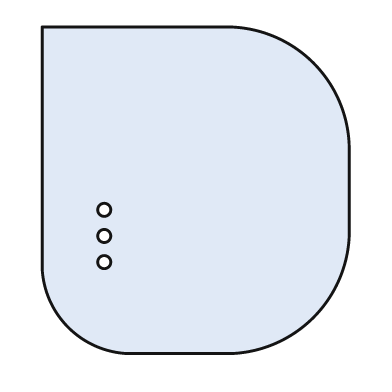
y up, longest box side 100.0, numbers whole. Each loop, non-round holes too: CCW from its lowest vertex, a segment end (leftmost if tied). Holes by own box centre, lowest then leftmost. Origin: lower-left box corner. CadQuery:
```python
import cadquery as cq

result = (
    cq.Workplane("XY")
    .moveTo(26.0, 0.0)
    .lineTo(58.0, 0.0)
    .threePointArc((83.0, 11.0), (94.0, 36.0))
    .lineTo(94.0, 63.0)
    .threePointArc((83.0, 89.0), (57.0, 100.0))
    .lineTo(0.0, 100.0)
    .lineTo(0.0, 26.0)
    .threePointArc((8.0, 8.0), (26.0, 0.0))
    .close()
    .moveTo(19.0, 28.0)
    .circle(2.0)
    .moveTo(19.0, 36.0)
    .circle(2.0)
    .moveTo(19.0, 44.0)
    .circle(2.0)
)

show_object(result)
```